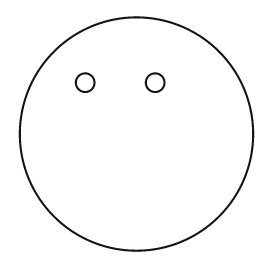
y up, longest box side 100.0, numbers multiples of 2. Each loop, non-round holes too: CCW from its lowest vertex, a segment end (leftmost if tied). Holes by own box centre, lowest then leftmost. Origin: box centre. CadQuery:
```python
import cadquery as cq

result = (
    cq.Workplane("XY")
    .moveTo(0.0, 0.0)
    .circle(50.0)
    .moveTo(-22.0, 22.0)
    .circle(4.0)
    .moveTo(8.0, 22.0)
    .circle(4.0)
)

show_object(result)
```